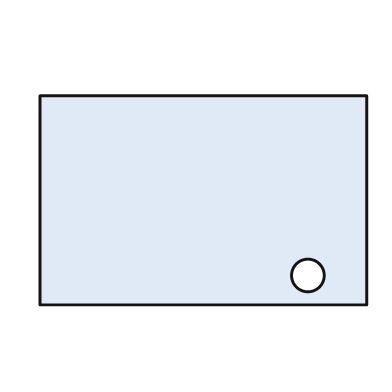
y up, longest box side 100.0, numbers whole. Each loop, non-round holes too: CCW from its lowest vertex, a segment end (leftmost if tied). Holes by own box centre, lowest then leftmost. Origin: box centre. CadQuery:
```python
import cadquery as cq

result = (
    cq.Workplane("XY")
    .moveTo(-50.0, -32.0)
    .lineTo(50.0, -32.0)
    .lineTo(50.0, 32.0)
    .lineTo(-50.0, 32.0)
    .close()
    .moveTo(32.0, -23.0)
    .circle(5.0)
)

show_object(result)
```